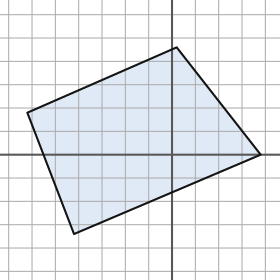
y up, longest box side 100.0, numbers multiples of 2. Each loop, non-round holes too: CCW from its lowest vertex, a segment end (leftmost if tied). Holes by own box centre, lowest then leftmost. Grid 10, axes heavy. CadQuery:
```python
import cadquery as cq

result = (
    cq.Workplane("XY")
    .moveTo(-42.0, -34.0)
    .lineTo(38.0, 0.0)
    .lineTo(2.0, 46.0)
    .lineTo(-62.0, 18.0)
    .close()
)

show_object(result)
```